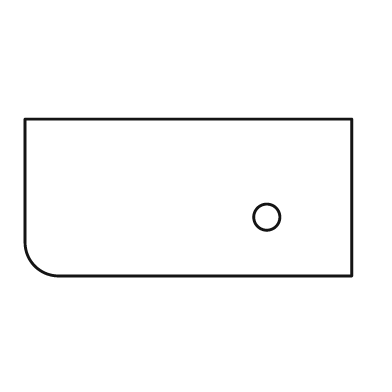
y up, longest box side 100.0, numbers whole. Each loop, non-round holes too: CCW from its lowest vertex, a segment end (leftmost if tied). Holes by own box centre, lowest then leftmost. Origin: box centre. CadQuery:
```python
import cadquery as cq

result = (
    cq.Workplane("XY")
    .moveTo(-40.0, -24.0)
    .lineTo(50.0, -24.0)
    .lineTo(50.0, 24.0)
    .lineTo(-50.0, 24.0)
    .lineTo(-50.0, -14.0)
    .threePointArc((-47.0, -21.0), (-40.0, -24.0))
    .close()
    .moveTo(24.0, -6.0)
    .circle(4.0)
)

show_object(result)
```